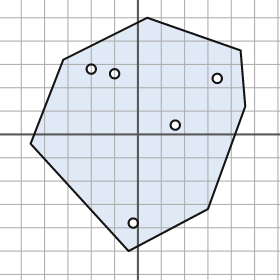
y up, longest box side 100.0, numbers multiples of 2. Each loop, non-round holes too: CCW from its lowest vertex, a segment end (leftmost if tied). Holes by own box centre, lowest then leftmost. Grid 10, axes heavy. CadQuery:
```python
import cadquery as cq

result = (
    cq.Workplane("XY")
    .moveTo(-4.0, -50.0)
    .lineTo(30.0, -32.0)
    .lineTo(46.0, 12.0)
    .lineTo(44.0, 36.0)
    .lineTo(4.0, 50.0)
    .lineTo(-32.0, 32.0)
    .lineTo(-46.0, -4.0)
    .close()
    .moveTo(-2.0, -38.0)
    .circle(2.0)
    .moveTo(16.0, 4.0)
    .circle(2.0)
    .moveTo(34.0, 24.0)
    .circle(2.0)
    .moveTo(-10.0, 26.0)
    .circle(2.0)
    .moveTo(-20.0, 28.0)
    .circle(2.0)
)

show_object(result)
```